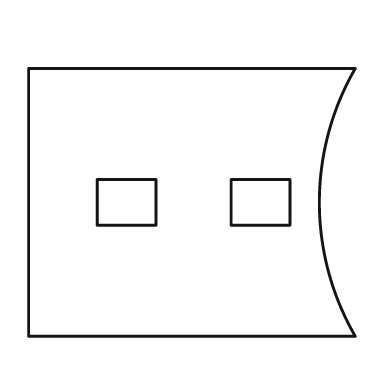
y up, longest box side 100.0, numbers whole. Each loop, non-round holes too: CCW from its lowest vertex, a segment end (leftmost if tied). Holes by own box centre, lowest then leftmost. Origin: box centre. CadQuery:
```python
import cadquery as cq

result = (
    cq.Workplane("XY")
    .moveTo(-50.0, -41.0)
    .lineTo(50.0, -41.0)
    .threePointArc((39.0, 0.0), (50.0, 41.0))
    .lineTo(-50.0, 41.0)
    .close()
    .moveTo(-29.0, -7.0)
    .lineTo(-11.0, -7.0)
    .lineTo(-11.0, 7.0)
    .lineTo(-29.0, 7.0)
    .close()
    .moveTo(12.0, -7.0)
    .lineTo(30.0, -7.0)
    .lineTo(30.0, 7.0)
    .lineTo(12.0, 7.0)
    .close()
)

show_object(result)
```